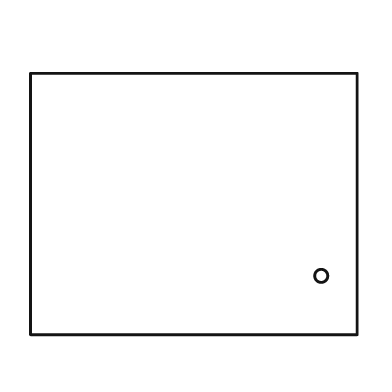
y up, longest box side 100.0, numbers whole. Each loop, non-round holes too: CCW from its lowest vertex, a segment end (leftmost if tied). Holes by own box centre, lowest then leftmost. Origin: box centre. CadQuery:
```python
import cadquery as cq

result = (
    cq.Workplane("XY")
    .moveTo(-50.0, -40.0)
    .lineTo(50.0, -40.0)
    .lineTo(50.0, 40.0)
    .lineTo(-50.0, 40.0)
    .close()
    .moveTo(39.0, -22.0)
    .circle(2.0)
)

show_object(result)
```